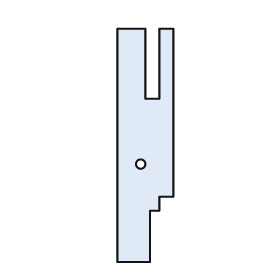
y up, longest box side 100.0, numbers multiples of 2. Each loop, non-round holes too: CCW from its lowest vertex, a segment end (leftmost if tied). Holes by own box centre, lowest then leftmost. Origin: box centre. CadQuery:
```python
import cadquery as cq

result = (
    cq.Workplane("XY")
    .moveTo(-12.0, -50.0)
    .lineTo(2.0, -50.0)
    .lineTo(2.0, -28.0)
    .lineTo(6.0, -28.0)
    .lineTo(6.0, -22.0)
    .lineTo(12.0, -22.0)
    .lineTo(12.0, 50.0)
    .lineTo(6.0, 50.0)
    .lineTo(6.0, 20.0)
    .lineTo(0.0, 20.0)
    .lineTo(0.0, 50.0)
    .lineTo(-12.0, 50.0)
    .close()
    .moveTo(-2.0, -8.0)
    .circle(2.0)
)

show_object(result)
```